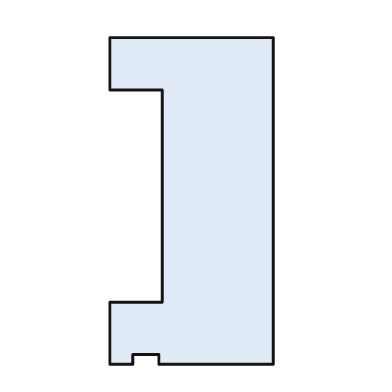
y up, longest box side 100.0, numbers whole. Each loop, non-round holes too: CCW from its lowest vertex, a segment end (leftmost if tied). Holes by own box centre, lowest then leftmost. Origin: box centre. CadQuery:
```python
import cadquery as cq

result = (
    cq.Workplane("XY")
    .moveTo(-25.0, -50.0)
    .lineTo(-18.0, -50.0)
    .lineTo(-18.0, -47.0)
    .lineTo(-10.0, -47.0)
    .lineTo(-10.0, -50.0)
    .lineTo(25.0, -50.0)
    .lineTo(25.0, 50.0)
    .lineTo(-25.0, 50.0)
    .lineTo(-25.0, 34.0)
    .lineTo(-9.0, 34.0)
    .lineTo(-9.0, -31.0)
    .lineTo(-25.0, -31.0)
    .close()
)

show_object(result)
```